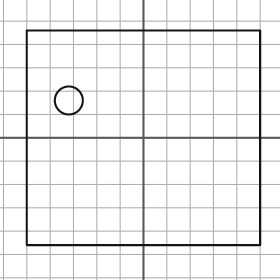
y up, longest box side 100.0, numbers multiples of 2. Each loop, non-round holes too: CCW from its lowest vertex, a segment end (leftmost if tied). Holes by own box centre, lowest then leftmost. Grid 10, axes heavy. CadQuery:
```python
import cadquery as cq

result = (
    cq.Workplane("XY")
    .moveTo(-50.0, -46.0)
    .lineTo(50.0, -46.0)
    .lineTo(50.0, 46.0)
    .lineTo(-50.0, 46.0)
    .close()
    .moveTo(-32.0, 16.0)
    .circle(6.0)
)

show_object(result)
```